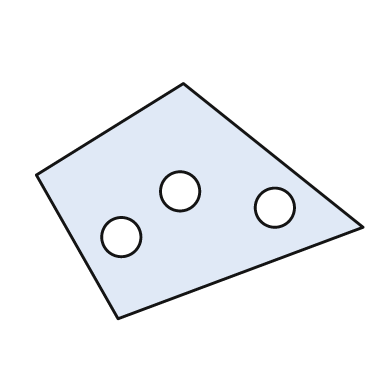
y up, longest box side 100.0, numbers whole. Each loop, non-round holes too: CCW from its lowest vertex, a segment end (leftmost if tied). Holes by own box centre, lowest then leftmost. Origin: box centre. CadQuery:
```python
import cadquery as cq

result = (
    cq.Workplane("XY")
    .moveTo(-25.0, -36.0)
    .lineTo(50.0, -8.0)
    .lineTo(-5.0, 36.0)
    .lineTo(-50.0, 8.0)
    .close()
    .moveTo(-24.0, -11.0)
    .circle(6.0)
    .moveTo(23.0, -2.0)
    .circle(6.0)
    .moveTo(-6.0, 3.0)
    .circle(6.0)
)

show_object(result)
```